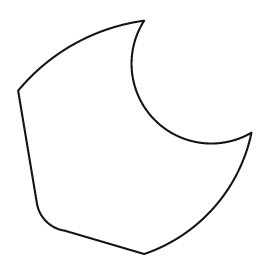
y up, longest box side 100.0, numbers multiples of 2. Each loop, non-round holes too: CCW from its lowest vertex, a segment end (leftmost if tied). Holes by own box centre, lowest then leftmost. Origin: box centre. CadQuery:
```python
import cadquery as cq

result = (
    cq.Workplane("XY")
    .moveTo(4.0, -50.0)
    .threePointArc((34.0, -30.0), (50.0, 2.0))
    .threePointArc((8.0, 8.0), (4.0, 50.0))
    .threePointArc((-26.0, 40.0), (-50.0, 20.0))
    .lineTo(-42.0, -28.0)
    .threePointArc((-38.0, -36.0), (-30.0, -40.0))
    .close()
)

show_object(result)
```